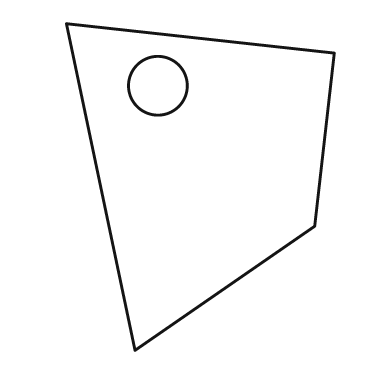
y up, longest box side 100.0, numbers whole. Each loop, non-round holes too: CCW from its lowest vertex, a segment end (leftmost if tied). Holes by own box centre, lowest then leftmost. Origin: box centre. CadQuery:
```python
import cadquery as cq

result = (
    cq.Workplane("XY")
    .moveTo(-20.0, -50.0)
    .lineTo(35.0, -12.0)
    .lineTo(41.0, 41.0)
    .lineTo(-41.0, 50.0)
    .close()
    .moveTo(-13.0, 31.0)
    .circle(9.0)
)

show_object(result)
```